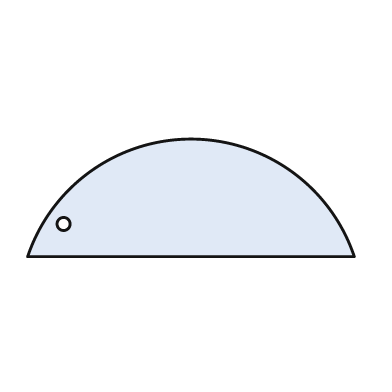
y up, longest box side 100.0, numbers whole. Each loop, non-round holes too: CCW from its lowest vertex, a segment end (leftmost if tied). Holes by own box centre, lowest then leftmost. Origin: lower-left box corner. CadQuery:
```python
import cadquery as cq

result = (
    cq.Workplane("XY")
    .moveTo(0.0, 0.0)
    .lineTo(100.0, 0.0)
    .threePointArc((50.0, 36.0), (0.0, 0.0))
    .close()
    .moveTo(11.0, 10.0)
    .circle(2.0)
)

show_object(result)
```